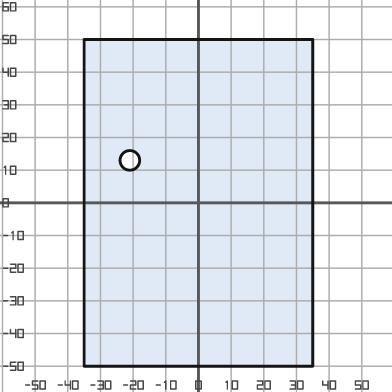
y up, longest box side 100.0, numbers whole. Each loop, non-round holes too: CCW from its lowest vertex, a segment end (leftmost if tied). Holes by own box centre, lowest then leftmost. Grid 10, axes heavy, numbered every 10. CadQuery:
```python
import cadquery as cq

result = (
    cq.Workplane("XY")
    .moveTo(-35.0, -50.0)
    .lineTo(35.0, -50.0)
    .lineTo(35.0, 50.0)
    .lineTo(-35.0, 50.0)
    .close()
    .moveTo(-21.0, 13.0)
    .circle(3.0)
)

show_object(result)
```